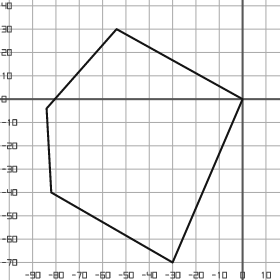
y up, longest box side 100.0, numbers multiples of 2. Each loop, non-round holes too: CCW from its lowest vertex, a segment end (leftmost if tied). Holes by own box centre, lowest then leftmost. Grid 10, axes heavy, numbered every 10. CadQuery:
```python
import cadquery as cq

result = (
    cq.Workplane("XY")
    .moveTo(-30.0, -70.0)
    .lineTo(0.0, 0.0)
    .lineTo(-54.0, 30.0)
    .lineTo(-84.0, -4.0)
    .lineTo(-82.0, -40.0)
    .close()
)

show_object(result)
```